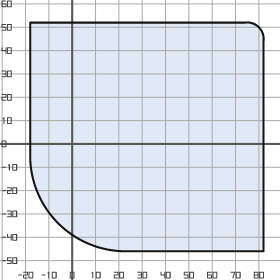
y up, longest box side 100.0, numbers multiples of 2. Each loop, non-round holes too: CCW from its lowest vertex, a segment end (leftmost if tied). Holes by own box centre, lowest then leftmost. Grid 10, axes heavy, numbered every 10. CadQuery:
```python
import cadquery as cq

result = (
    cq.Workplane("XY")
    .moveTo(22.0, -46.0)
    .lineTo(82.0, -46.0)
    .lineTo(82.0, 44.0)
    .threePointArc((80.0, 50.0), (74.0, 52.0))
    .lineTo(-18.0, 52.0)
    .lineTo(-18.0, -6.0)
    .threePointArc((-6.0, -34.0), (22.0, -46.0))
    .close()
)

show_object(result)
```